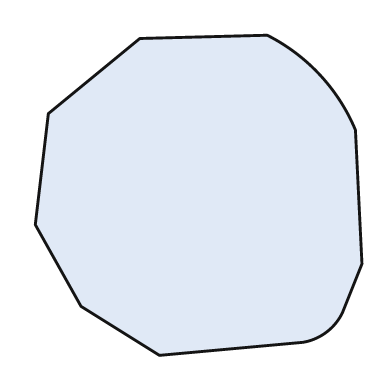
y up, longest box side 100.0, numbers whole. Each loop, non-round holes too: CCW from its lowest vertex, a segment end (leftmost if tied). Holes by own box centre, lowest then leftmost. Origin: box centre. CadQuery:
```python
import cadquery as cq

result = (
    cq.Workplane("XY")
    .moveTo(-12.0, -49.0)
    .lineTo(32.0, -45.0)
    .threePointArc((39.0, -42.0), (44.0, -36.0))
    .lineTo(50.0, -21.0)
    .lineTo(48.0, 20.0)
    .threePointArc((37.0, 37.0), (21.0, 49.0))
    .lineTo(-18.0, 48.0)
    .lineTo(-46.0, 25.0)
    .lineTo(-50.0, -9.0)
    .lineTo(-36.0, -34.0)
    .close()
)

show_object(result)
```